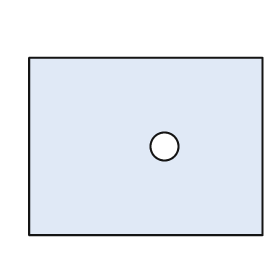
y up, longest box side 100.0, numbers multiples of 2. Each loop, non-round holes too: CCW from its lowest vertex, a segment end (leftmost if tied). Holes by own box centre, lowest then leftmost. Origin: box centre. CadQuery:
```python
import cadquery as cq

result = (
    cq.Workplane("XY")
    .moveTo(-50.0, -38.0)
    .lineTo(50.0, -38.0)
    .lineTo(50.0, 38.0)
    .lineTo(-50.0, 38.0)
    .close()
    .moveTo(8.0, 0.0)
    .circle(6.0)
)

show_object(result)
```